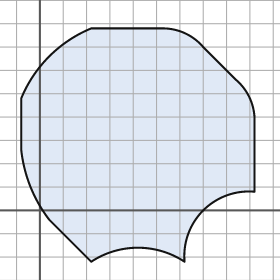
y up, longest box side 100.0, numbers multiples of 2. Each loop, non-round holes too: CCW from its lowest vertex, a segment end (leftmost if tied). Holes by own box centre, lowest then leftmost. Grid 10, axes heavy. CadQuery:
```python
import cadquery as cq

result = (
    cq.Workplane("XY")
    .moveTo(22.0, -22.0)
    .threePointArc((42.0, -16.0), (62.0, -22.0))
    .threePointArc((70.0, 0.0), (92.0, 8.0))
    .lineTo(92.0, 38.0)
    .threePointArc((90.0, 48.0), (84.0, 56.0))
    .lineTo(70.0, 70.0)
    .threePointArc((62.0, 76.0), (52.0, 78.0))
    .lineTo(22.0, 78.0)
    .threePointArc((4.0, 66.0), (-8.0, 48.0))
    .lineTo(-8.0, 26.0)
    .threePointArc((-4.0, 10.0), (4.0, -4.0))
    .close()
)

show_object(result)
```